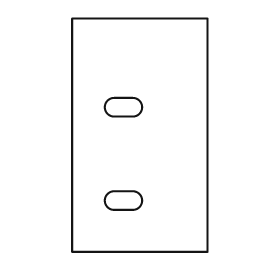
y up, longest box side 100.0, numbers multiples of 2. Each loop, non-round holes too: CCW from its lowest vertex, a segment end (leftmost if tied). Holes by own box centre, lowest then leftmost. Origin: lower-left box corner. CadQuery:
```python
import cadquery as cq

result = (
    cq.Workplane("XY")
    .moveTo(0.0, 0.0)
    .lineTo(58.0, 0.0)
    .lineTo(58.0, 100.0)
    .lineTo(0.0, 100.0)
    .close()
    .moveTo(18.0, 18.0)
    .lineTo(26.0, 18.0)
    .threePointArc((30.0, 22.0), (26.0, 26.0))
    .lineTo(18.0, 26.0)
    .threePointArc((14.0, 22.0), (18.0, 18.0))
    .close()
    .moveTo(18.0, 58.0)
    .lineTo(26.0, 58.0)
    .threePointArc((30.0, 62.0), (26.0, 66.0))
    .lineTo(18.0, 66.0)
    .threePointArc((14.0, 62.0), (18.0, 58.0))
    .close()
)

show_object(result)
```